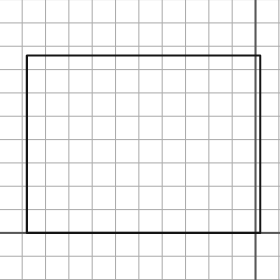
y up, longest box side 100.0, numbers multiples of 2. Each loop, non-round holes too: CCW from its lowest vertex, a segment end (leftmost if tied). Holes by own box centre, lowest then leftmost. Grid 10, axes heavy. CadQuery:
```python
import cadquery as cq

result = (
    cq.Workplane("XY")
    .moveTo(-98.0, 0.0)
    .lineTo(2.0, 0.0)
    .lineTo(2.0, 76.0)
    .lineTo(-98.0, 76.0)
    .close()
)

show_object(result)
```